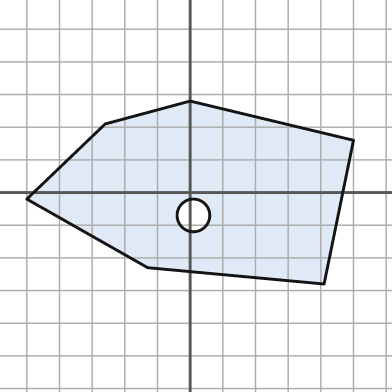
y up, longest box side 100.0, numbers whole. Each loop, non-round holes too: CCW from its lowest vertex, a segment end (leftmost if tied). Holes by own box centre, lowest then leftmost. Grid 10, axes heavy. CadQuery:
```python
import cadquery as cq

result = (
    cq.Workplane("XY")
    .moveTo(41.0, -28.0)
    .lineTo(50.0, 16.0)
    .lineTo(0.0, 28.0)
    .lineTo(-26.0, 21.0)
    .lineTo(-50.0, -2.0)
    .lineTo(-13.0, -23.0)
    .close()
    .moveTo(1.0, -7.0)
    .circle(5.0)
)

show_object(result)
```